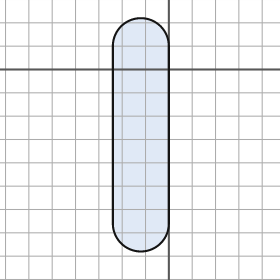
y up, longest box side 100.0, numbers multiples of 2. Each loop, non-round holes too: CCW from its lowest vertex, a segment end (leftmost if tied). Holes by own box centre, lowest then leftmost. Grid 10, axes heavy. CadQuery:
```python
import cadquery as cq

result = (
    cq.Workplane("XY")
    .moveTo(-24.0, -66.0)
    .threePointArc((-12.0, -78.0), (0.0, -66.0))
    .lineTo(0.0, 10.0)
    .threePointArc((-12.0, 22.0), (-24.0, 10.0))
    .close()
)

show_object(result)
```